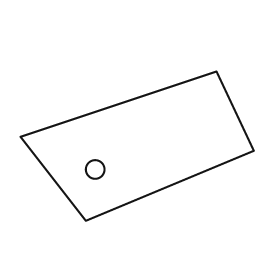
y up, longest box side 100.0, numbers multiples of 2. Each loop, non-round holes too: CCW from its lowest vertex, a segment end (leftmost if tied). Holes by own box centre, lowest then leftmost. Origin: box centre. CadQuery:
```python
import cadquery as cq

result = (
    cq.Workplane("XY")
    .moveTo(-22.0, -32.0)
    .lineTo(50.0, -2.0)
    .lineTo(34.0, 32.0)
    .lineTo(-50.0, 4.0)
    .close()
    .moveTo(-18.0, -10.0)
    .circle(4.0)
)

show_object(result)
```